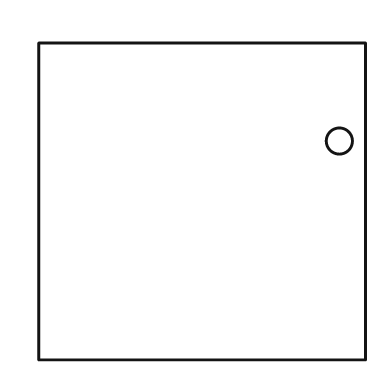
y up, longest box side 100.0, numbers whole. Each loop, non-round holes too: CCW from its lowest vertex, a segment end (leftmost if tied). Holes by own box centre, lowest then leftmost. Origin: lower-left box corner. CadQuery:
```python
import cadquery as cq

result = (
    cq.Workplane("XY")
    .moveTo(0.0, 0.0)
    .lineTo(100.0, 0.0)
    .lineTo(100.0, 97.0)
    .lineTo(0.0, 97.0)
    .close()
    .moveTo(92.0, 67.0)
    .circle(4.0)
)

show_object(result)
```